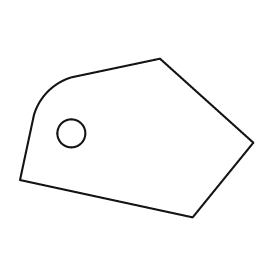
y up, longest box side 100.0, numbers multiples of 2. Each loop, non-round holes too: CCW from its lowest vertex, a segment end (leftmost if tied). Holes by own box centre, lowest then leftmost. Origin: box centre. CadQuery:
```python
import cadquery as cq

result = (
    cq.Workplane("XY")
    .moveTo(24.0, -34.0)
    .lineTo(50.0, -2.0)
    .lineTo(10.0, 34.0)
    .lineTo(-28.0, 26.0)
    .threePointArc((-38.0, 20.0), (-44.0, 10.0))
    .lineTo(-50.0, -18.0)
    .close()
    .moveTo(-28.0, 2.0)
    .circle(6.0)
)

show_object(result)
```